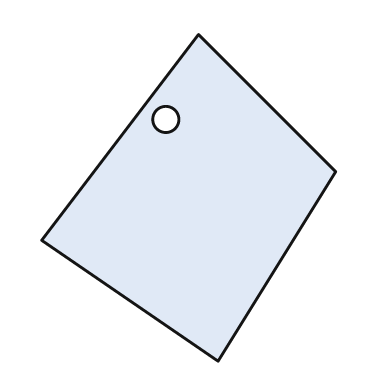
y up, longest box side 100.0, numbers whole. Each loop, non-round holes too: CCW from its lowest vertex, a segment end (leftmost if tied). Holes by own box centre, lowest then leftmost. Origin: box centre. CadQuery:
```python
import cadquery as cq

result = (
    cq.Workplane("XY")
    .moveTo(9.0, -50.0)
    .lineTo(45.0, 8.0)
    .lineTo(3.0, 50.0)
    .lineTo(-45.0, -13.0)
    .close()
    .moveTo(-7.0, 24.0)
    .circle(4.0)
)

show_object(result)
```